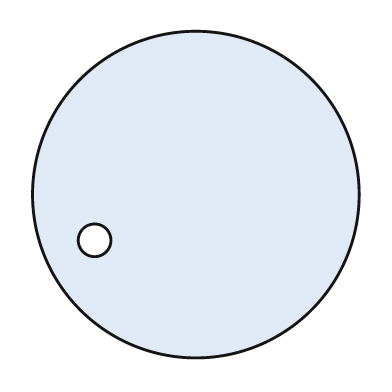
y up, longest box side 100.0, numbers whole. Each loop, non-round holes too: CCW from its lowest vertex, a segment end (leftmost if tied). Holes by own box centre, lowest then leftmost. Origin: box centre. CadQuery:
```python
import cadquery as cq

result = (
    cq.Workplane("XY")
    .moveTo(0.0, 0.0)
    .circle(50.0)
    .moveTo(-31.0, -14.0)
    .circle(5.0)
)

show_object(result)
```